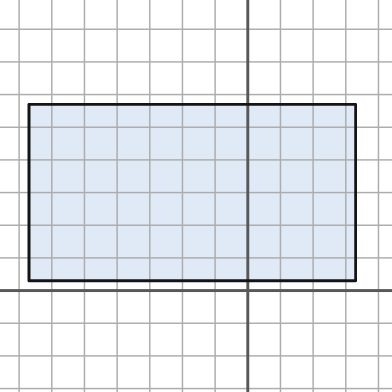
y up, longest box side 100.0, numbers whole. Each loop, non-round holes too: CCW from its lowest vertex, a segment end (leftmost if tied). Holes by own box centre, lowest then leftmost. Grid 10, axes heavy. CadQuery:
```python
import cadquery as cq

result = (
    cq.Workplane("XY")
    .moveTo(-67.0, 3.0)
    .lineTo(33.0, 3.0)
    .lineTo(33.0, 57.0)
    .lineTo(-67.0, 57.0)
    .close()
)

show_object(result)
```